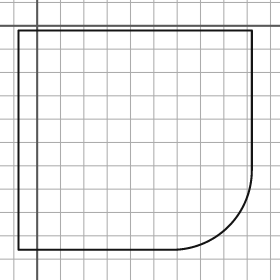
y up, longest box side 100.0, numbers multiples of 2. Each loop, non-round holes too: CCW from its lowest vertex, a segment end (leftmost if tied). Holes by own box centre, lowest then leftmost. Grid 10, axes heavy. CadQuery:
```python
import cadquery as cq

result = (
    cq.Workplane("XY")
    .moveTo(-8.0, -96.0)
    .lineTo(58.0, -96.0)
    .threePointArc((82.0, -86.0), (92.0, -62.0))
    .lineTo(92.0, -2.0)
    .lineTo(-8.0, -2.0)
    .close()
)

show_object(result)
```